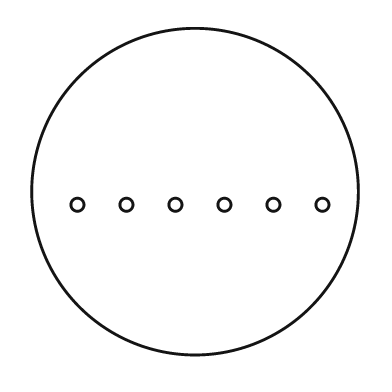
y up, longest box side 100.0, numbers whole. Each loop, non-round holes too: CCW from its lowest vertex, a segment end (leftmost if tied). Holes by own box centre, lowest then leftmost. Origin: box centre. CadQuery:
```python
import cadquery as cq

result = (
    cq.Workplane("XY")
    .moveTo(0.0, 0.0)
    .circle(50.0)
    .moveTo(-36.0, -4.0)
    .circle(2.0)
    .moveTo(-21.0, -4.0)
    .circle(2.0)
    .moveTo(-6.0, -4.0)
    .circle(2.0)
    .moveTo(9.0, -4.0)
    .circle(2.0)
    .moveTo(24.0, -4.0)
    .circle(2.0)
    .moveTo(39.0, -4.0)
    .circle(2.0)
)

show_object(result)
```